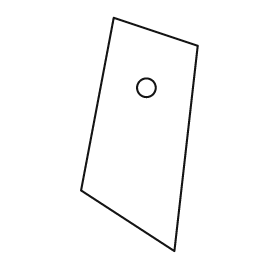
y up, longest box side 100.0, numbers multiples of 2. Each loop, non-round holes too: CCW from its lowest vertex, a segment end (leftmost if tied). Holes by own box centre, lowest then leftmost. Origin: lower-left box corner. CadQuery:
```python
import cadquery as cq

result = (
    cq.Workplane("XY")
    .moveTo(40.0, 0.0)
    .lineTo(50.0, 88.0)
    .lineTo(14.0, 100.0)
    .lineTo(0.0, 26.0)
    .close()
    .moveTo(28.0, 70.0)
    .circle(4.0)
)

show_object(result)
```